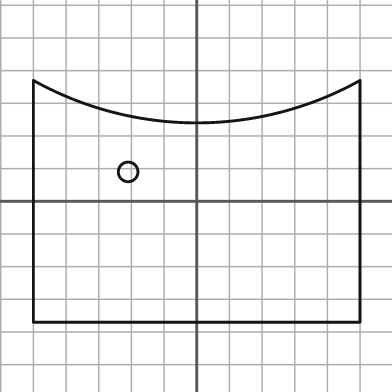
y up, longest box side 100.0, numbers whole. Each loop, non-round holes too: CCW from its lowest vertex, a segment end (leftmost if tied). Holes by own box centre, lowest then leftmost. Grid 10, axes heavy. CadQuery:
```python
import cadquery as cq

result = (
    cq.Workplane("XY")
    .moveTo(-50.0, -37.0)
    .lineTo(50.0, -37.0)
    .lineTo(50.0, 37.0)
    .threePointArc((0.0, 24.0), (-50.0, 37.0))
    .close()
    .moveTo(-21.0, 9.0)
    .circle(3.0)
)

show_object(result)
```